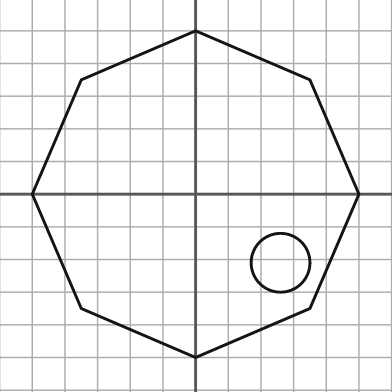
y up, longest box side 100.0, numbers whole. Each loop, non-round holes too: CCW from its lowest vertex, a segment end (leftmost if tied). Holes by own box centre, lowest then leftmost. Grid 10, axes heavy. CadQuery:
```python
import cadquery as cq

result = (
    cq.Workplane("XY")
    .moveTo(0.0, -50.0)
    .lineTo(35.0, -35.0)
    .lineTo(50.0, 0.0)
    .lineTo(35.0, 35.0)
    .lineTo(0.0, 50.0)
    .lineTo(-35.0, 35.0)
    .lineTo(-50.0, 0.0)
    .lineTo(-35.0, -35.0)
    .close()
    .moveTo(26.0, -21.0)
    .circle(9.0)
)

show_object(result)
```